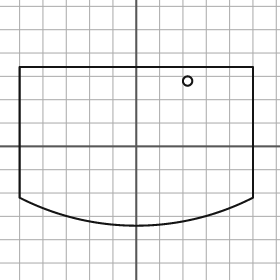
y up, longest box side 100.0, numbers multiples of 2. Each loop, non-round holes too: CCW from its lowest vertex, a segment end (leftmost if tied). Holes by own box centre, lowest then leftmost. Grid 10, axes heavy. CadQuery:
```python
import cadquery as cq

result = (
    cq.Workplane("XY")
    .moveTo(-50.0, -22.0)
    .threePointArc((0.0, -34.0), (50.0, -22.0))
    .lineTo(50.0, 34.0)
    .lineTo(-50.0, 34.0)
    .close()
    .moveTo(22.0, 28.0)
    .circle(2.0)
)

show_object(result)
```